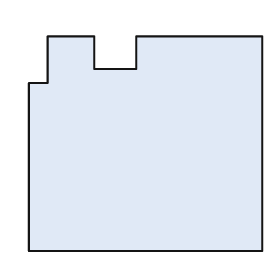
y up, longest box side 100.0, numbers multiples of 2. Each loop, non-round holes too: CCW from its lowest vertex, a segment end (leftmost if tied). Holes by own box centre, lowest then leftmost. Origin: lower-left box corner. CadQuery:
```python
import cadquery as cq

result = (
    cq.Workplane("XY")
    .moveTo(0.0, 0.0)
    .lineTo(100.0, 0.0)
    .lineTo(100.0, 92.0)
    .lineTo(46.0, 92.0)
    .lineTo(46.0, 78.0)
    .lineTo(28.0, 78.0)
    .lineTo(28.0, 92.0)
    .lineTo(8.0, 92.0)
    .lineTo(8.0, 72.0)
    .lineTo(0.0, 72.0)
    .close()
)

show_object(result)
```